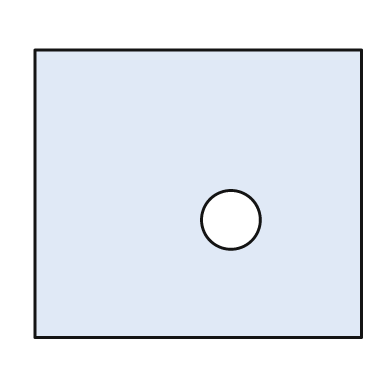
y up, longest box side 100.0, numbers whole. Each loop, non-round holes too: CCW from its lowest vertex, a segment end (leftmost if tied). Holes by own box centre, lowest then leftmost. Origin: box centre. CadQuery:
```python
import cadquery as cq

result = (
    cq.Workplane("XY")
    .moveTo(-50.0, -44.0)
    .lineTo(50.0, -44.0)
    .lineTo(50.0, 44.0)
    .lineTo(-50.0, 44.0)
    .close()
    .moveTo(10.0, -8.0)
    .circle(9.0)
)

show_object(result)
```